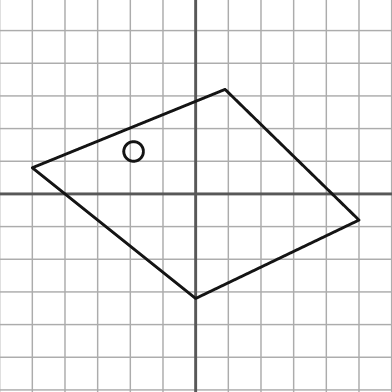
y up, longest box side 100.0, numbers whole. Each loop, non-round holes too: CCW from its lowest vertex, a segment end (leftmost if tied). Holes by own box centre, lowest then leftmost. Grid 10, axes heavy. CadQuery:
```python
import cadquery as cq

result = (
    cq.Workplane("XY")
    .moveTo(0.0, -32.0)
    .lineTo(50.0, -8.0)
    .lineTo(9.0, 32.0)
    .lineTo(-50.0, 8.0)
    .close()
    .moveTo(-19.0, 13.0)
    .circle(3.0)
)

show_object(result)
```